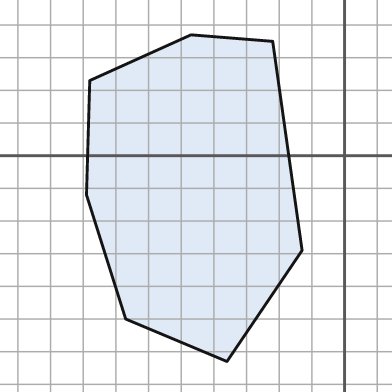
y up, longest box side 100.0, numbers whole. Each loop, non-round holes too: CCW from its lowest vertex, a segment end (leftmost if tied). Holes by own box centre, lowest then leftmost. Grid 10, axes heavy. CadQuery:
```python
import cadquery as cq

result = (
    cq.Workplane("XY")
    .moveTo(-36.0, -63.0)
    .lineTo(-13.0, -29.0)
    .lineTo(-22.0, 35.0)
    .lineTo(-47.0, 37.0)
    .lineTo(-78.0, 23.0)
    .lineTo(-79.0, -12.0)
    .lineTo(-67.0, -50.0)
    .close()
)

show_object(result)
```